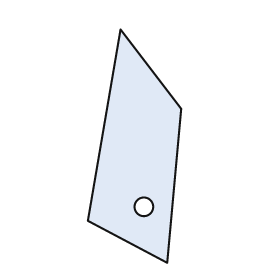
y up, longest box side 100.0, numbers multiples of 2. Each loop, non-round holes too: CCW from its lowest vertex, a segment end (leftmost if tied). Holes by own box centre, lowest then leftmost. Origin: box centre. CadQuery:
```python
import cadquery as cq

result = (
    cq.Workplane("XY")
    .moveTo(14.0, -50.0)
    .lineTo(20.0, 16.0)
    .lineTo(-6.0, 50.0)
    .lineTo(-20.0, -32.0)
    .close()
    .moveTo(4.0, -26.0)
    .circle(4.0)
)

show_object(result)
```